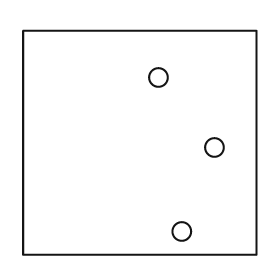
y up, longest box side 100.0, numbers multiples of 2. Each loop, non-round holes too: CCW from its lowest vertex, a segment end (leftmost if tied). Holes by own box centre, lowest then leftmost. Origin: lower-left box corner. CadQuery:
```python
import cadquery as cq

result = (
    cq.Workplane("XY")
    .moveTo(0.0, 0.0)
    .lineTo(100.0, 0.0)
    .lineTo(100.0, 96.0)
    .lineTo(0.0, 96.0)
    .close()
    .moveTo(68.0, 10.0)
    .circle(4.0)
    .moveTo(82.0, 46.0)
    .circle(4.0)
    .moveTo(58.0, 76.0)
    .circle(4.0)
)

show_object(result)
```